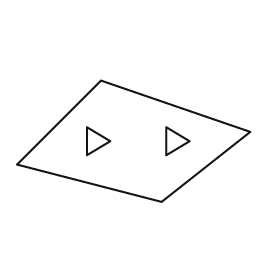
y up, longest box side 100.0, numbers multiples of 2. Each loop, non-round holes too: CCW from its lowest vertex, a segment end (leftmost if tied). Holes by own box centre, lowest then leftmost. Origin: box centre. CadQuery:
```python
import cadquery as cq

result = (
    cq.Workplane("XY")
    .moveTo(12.0, -26.0)
    .lineTo(50.0, 4.0)
    .lineTo(-14.0, 26.0)
    .lineTo(-50.0, -10.0)
    .close()
    .moveTo(-20.0, -6.0)
    .lineTo(-10.0, 0.0)
    .lineTo(-20.0, 6.0)
    .close()
    .moveTo(14.0, -6.0)
    .lineTo(24.0, 0.0)
    .lineTo(14.0, 6.0)
    .close()
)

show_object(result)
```